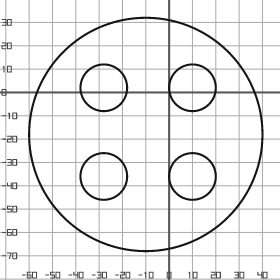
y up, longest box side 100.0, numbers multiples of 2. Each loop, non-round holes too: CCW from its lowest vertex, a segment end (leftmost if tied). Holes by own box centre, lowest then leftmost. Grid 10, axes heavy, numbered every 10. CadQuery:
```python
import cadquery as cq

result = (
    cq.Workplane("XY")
    .moveTo(-10.0, -18.0)
    .circle(50.0)
    .moveTo(-28.0, -36.0)
    .circle(10.0)
    .moveTo(10.0, -36.0)
    .circle(10.0)
    .moveTo(-28.0, 2.0)
    .circle(10.0)
    .moveTo(10.0, 2.0)
    .circle(10.0)
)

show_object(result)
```